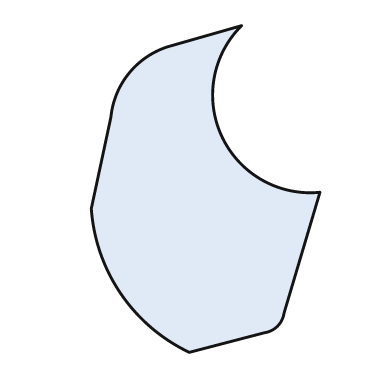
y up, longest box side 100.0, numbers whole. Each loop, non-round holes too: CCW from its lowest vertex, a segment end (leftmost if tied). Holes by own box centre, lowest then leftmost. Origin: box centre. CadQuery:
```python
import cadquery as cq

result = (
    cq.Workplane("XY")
    .moveTo(-5.0, -50.0)
    .lineTo(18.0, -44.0)
    .threePointArc((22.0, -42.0), (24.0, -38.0))
    .lineTo(35.0, -1.0)
    .threePointArc((5.0, 16.0), (11.0, 50.0))
    .lineTo(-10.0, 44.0)
    .threePointArc((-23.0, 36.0), (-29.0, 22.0))
    .lineTo(-35.0, -6.0)
    .threePointArc((-26.0, -32.0), (-5.0, -50.0))
    .close()
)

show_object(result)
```